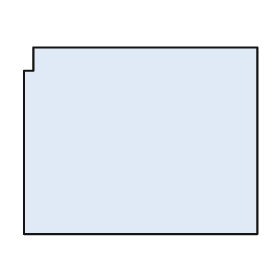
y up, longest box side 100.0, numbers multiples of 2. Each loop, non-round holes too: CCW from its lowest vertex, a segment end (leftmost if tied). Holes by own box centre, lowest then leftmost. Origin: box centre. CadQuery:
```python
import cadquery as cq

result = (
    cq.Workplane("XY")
    .moveTo(-50.0, -40.0)
    .lineTo(50.0, -40.0)
    .lineTo(50.0, 40.0)
    .lineTo(-46.0, 40.0)
    .lineTo(-46.0, 30.0)
    .lineTo(-50.0, 30.0)
    .close()
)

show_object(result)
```